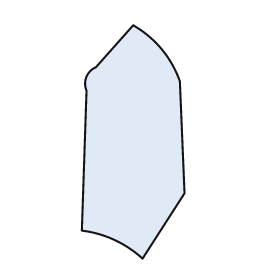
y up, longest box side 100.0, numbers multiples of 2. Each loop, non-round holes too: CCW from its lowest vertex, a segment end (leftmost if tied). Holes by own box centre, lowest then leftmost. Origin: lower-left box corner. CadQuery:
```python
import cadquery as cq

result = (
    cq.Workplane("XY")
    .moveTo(26.0, 0.0)
    .lineTo(44.0, 28.0)
    .lineTo(42.0, 76.0)
    .threePointArc((34.0, 90.0), (22.0, 100.0))
    .lineTo(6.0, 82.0)
    .threePointArc((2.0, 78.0), (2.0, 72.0))
    .lineTo(0.0, 12.0)
    .threePointArc((14.0, 8.0), (26.0, 0.0))
    .close()
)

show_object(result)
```